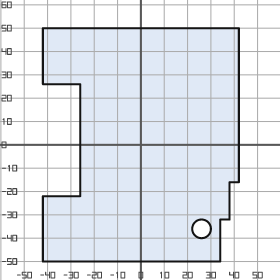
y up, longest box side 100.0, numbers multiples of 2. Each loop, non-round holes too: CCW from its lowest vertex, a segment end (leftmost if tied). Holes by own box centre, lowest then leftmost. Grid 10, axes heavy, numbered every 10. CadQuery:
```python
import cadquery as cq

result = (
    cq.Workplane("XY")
    .moveTo(-42.0, -50.0)
    .lineTo(34.0, -50.0)
    .lineTo(34.0, -32.0)
    .lineTo(38.0, -32.0)
    .lineTo(38.0, -16.0)
    .lineTo(42.0, -16.0)
    .lineTo(42.0, 50.0)
    .lineTo(-42.0, 50.0)
    .lineTo(-42.0, 26.0)
    .lineTo(-26.0, 26.0)
    .lineTo(-26.0, -22.0)
    .lineTo(-42.0, -22.0)
    .close()
    .moveTo(26.0, -36.0)
    .circle(4.0)
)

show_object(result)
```